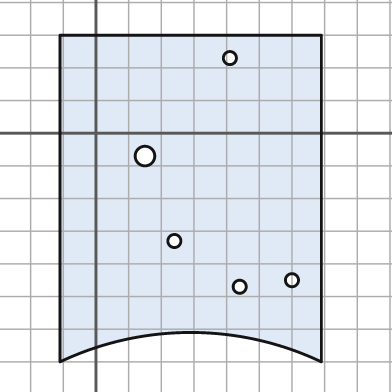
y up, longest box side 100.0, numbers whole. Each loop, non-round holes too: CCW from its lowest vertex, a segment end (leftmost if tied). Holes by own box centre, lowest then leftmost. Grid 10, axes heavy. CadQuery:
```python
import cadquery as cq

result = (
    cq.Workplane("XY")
    .moveTo(-11.0, -70.0)
    .threePointArc((29.0, -61.0), (69.0, -70.0))
    .lineTo(69.0, 30.0)
    .lineTo(-11.0, 30.0)
    .close()
    .moveTo(44.0, -47.0)
    .circle(2.0)
    .moveTo(60.0, -45.0)
    .circle(2.0)
    .moveTo(24.0, -33.0)
    .circle(2.0)
    .moveTo(15.0, -7.0)
    .circle(3.0)
    .moveTo(41.0, 23.0)
    .circle(2.0)
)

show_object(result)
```